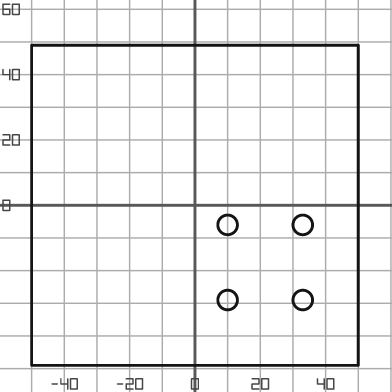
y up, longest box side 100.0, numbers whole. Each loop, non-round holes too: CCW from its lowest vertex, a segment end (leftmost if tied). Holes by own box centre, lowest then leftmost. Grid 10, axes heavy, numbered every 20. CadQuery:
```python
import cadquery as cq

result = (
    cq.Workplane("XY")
    .moveTo(-50.0, -49.0)
    .lineTo(50.0, -49.0)
    .lineTo(50.0, 49.0)
    .lineTo(-50.0, 49.0)
    .close()
    .moveTo(10.0, -29.0)
    .circle(3.0)
    .moveTo(33.0, -29.0)
    .circle(3.0)
    .moveTo(10.0, -6.0)
    .circle(3.0)
    .moveTo(33.0, -6.0)
    .circle(3.0)
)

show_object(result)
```